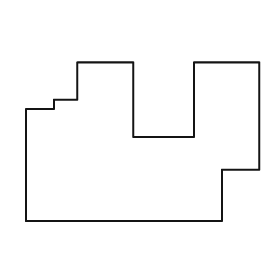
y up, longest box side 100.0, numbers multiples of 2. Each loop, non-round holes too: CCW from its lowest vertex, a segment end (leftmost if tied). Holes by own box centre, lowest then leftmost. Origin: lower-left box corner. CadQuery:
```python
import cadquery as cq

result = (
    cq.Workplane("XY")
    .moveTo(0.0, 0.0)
    .lineTo(84.0, 0.0)
    .lineTo(84.0, 22.0)
    .lineTo(100.0, 22.0)
    .lineTo(100.0, 68.0)
    .lineTo(72.0, 68.0)
    .lineTo(72.0, 36.0)
    .lineTo(46.0, 36.0)
    .lineTo(46.0, 68.0)
    .lineTo(22.0, 68.0)
    .lineTo(22.0, 52.0)
    .lineTo(12.0, 52.0)
    .lineTo(12.0, 48.0)
    .lineTo(0.0, 48.0)
    .close()
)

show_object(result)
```